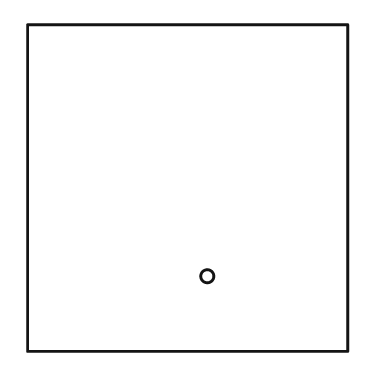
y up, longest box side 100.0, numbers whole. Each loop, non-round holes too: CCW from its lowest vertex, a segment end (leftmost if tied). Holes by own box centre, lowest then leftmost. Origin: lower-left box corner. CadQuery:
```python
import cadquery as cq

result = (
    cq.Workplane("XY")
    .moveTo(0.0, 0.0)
    .lineTo(98.0, 0.0)
    .lineTo(98.0, 100.0)
    .lineTo(0.0, 100.0)
    .close()
    .moveTo(55.0, 23.0)
    .circle(2.0)
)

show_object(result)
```